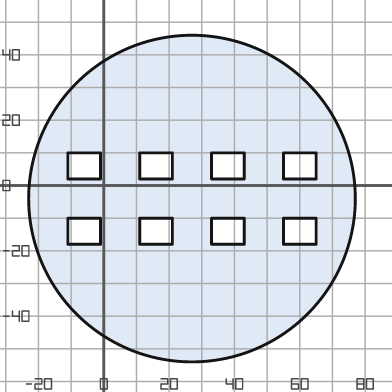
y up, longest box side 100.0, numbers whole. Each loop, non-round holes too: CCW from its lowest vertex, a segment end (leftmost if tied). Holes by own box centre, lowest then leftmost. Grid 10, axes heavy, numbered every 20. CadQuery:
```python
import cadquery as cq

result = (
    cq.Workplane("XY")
    .moveTo(27.0, -4.0)
    .circle(50.0)
    .moveTo(-11.0, -18.0)
    .lineTo(-1.0, -18.0)
    .lineTo(-1.0, -10.0)
    .lineTo(-11.0, -10.0)
    .close()
    .moveTo(11.0, -18.0)
    .lineTo(21.0, -18.0)
    .lineTo(21.0, -10.0)
    .lineTo(11.0, -10.0)
    .close()
    .moveTo(33.0, -18.0)
    .lineTo(43.0, -18.0)
    .lineTo(43.0, -10.0)
    .lineTo(33.0, -10.0)
    .close()
    .moveTo(55.0, -18.0)
    .lineTo(65.0, -18.0)
    .lineTo(65.0, -10.0)
    .lineTo(55.0, -10.0)
    .close()
    .moveTo(-11.0, 2.0)
    .lineTo(-1.0, 2.0)
    .lineTo(-1.0, 10.0)
    .lineTo(-11.0, 10.0)
    .close()
    .moveTo(11.0, 2.0)
    .lineTo(21.0, 2.0)
    .lineTo(21.0, 10.0)
    .lineTo(11.0, 10.0)
    .close()
    .moveTo(33.0, 2.0)
    .lineTo(43.0, 2.0)
    .lineTo(43.0, 10.0)
    .lineTo(33.0, 10.0)
    .close()
    .moveTo(55.0, 2.0)
    .lineTo(65.0, 2.0)
    .lineTo(65.0, 10.0)
    .lineTo(55.0, 10.0)
    .close()
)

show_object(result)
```